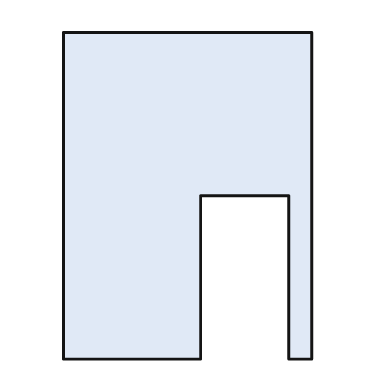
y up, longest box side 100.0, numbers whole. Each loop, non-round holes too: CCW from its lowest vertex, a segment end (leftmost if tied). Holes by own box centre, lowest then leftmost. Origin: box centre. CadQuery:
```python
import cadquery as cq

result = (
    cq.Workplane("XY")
    .moveTo(-38.0, -50.0)
    .lineTo(4.0, -50.0)
    .lineTo(4.0, 0.0)
    .lineTo(31.0, 0.0)
    .lineTo(31.0, -50.0)
    .lineTo(38.0, -50.0)
    .lineTo(38.0, 50.0)
    .lineTo(-38.0, 50.0)
    .close()
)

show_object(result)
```